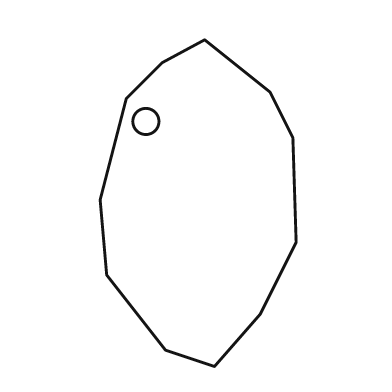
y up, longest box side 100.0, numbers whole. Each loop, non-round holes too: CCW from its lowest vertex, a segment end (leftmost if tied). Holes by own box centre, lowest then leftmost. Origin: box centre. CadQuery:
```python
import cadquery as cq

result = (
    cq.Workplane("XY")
    .moveTo(5.0, -50.0)
    .lineTo(19.0, -34.0)
    .lineTo(30.0, -12.0)
    .lineTo(29.0, 20.0)
    .lineTo(22.0, 34.0)
    .lineTo(2.0, 50.0)
    .lineTo(-11.0, 43.0)
    .lineTo(-22.0, 32.0)
    .lineTo(-30.0, 1.0)
    .lineTo(-28.0, -22.0)
    .lineTo(-10.0, -45.0)
    .close()
    .moveTo(-16.0, 25.0)
    .circle(4.0)
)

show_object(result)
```